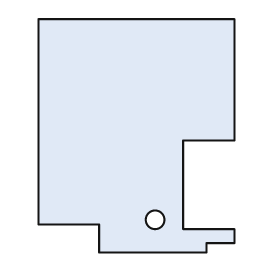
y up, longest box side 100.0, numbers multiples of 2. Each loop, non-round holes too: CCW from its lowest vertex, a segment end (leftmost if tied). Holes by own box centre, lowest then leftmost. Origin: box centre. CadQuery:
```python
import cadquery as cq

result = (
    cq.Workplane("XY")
    .moveTo(-16.0, -50.0)
    .lineTo(30.0, -50.0)
    .lineTo(30.0, -46.0)
    .lineTo(42.0, -46.0)
    .lineTo(42.0, -40.0)
    .lineTo(20.0, -40.0)
    .lineTo(20.0, -2.0)
    .lineTo(42.0, -2.0)
    .lineTo(42.0, 50.0)
    .lineTo(-42.0, 50.0)
    .lineTo(-42.0, -38.0)
    .lineTo(-16.0, -38.0)
    .close()
    .moveTo(8.0, -36.0)
    .circle(4.0)
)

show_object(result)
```